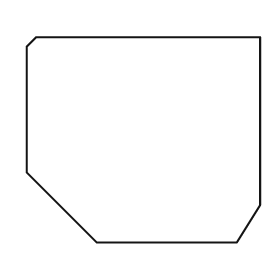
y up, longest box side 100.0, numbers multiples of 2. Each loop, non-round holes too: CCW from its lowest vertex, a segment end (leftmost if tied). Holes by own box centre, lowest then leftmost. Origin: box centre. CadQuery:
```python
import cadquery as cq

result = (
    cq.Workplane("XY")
    .moveTo(-20.0, -44.0)
    .lineTo(40.0, -44.0)
    .lineTo(50.0, -28.0)
    .lineTo(50.0, 44.0)
    .lineTo(-46.0, 44.0)
    .lineTo(-50.0, 40.0)
    .lineTo(-50.0, -14.0)
    .close()
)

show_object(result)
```